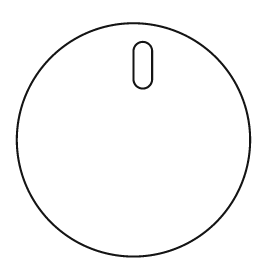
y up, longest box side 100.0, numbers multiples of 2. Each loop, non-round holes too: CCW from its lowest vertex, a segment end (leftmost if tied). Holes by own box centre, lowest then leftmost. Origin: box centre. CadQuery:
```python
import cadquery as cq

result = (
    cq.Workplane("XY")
    .moveTo(0.0, 0.0)
    .circle(50.0)
    .moveTo(0.0, 26.0)
    .threePointArc((4.0, 22.0), (8.0, 26.0))
    .lineTo(8.0, 38.0)
    .threePointArc((4.0, 42.0), (0.0, 38.0))
    .close()
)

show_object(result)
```